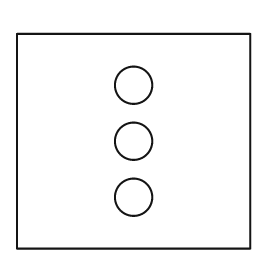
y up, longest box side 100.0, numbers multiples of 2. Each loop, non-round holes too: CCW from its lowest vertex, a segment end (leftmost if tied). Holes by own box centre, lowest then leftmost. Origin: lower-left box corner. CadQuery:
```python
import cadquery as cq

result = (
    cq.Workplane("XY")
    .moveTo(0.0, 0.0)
    .lineTo(100.0, 0.0)
    .lineTo(100.0, 92.0)
    .lineTo(0.0, 92.0)
    .close()
    .moveTo(50.0, 22.0)
    .circle(8.0)
    .moveTo(50.0, 46.0)
    .circle(8.0)
    .moveTo(50.0, 70.0)
    .circle(8.0)
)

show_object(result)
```